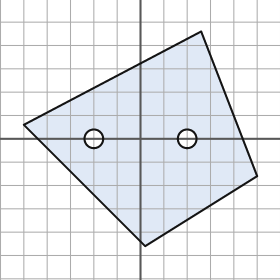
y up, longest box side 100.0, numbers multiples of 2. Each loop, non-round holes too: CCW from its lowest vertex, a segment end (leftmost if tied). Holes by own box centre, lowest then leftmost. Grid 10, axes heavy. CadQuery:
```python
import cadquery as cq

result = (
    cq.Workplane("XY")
    .moveTo(2.0, -46.0)
    .lineTo(50.0, -16.0)
    .lineTo(26.0, 46.0)
    .lineTo(-50.0, 6.0)
    .close()
    .moveTo(-20.0, 0.0)
    .circle(4.0)
    .moveTo(20.0, 0.0)
    .circle(4.0)
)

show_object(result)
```